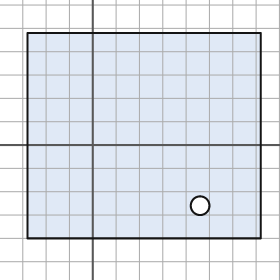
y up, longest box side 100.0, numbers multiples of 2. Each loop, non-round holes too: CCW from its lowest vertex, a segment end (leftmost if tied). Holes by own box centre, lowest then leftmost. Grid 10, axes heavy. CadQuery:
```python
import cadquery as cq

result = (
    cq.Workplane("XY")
    .moveTo(-28.0, -40.0)
    .lineTo(72.0, -40.0)
    .lineTo(72.0, 48.0)
    .lineTo(-28.0, 48.0)
    .close()
    .moveTo(46.0, -26.0)
    .circle(4.0)
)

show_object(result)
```